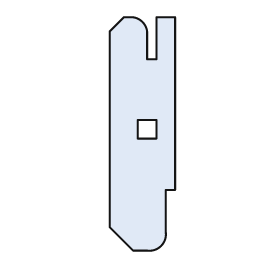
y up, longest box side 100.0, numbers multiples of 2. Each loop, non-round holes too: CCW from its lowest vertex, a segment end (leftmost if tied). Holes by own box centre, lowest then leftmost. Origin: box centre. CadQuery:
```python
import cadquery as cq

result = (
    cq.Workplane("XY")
    .moveTo(-4.0, -50.0)
    .lineTo(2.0, -50.0)
    .threePointArc((8.0, -48.0), (10.0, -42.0))
    .lineTo(10.0, -24.0)
    .lineTo(14.0, -24.0)
    .lineTo(14.0, 50.0)
    .lineTo(6.0, 50.0)
    .lineTo(6.0, 32.0)
    .lineTo(2.0, 32.0)
    .lineTo(2.0, 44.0)
    .threePointArc((0.0, 48.0), (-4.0, 50.0))
    .lineTo(-8.0, 50.0)
    .lineTo(-14.0, 44.0)
    .lineTo(-14.0, -40.0)
    .close()
    .moveTo(-2.0, -2.0)
    .lineTo(6.0, -2.0)
    .lineTo(6.0, 6.0)
    .lineTo(-2.0, 6.0)
    .close()
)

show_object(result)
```